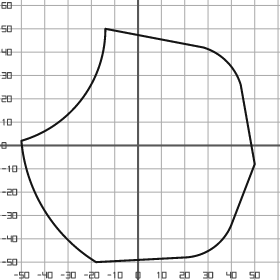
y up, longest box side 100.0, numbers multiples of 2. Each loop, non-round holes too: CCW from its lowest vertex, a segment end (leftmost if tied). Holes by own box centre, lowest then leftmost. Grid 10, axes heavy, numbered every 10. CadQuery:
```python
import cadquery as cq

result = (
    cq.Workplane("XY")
    .moveTo(-18.0, -50.0)
    .lineTo(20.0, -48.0)
    .threePointArc((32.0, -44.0), (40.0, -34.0))
    .lineTo(50.0, -8.0)
    .lineTo(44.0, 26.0)
    .threePointArc((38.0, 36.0), (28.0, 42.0))
    .lineTo(-14.0, 50.0)
    .threePointArc((-24.0, 20.0), (-50.0, 2.0))
    .threePointArc((-40.0, -28.0), (-18.0, -50.0))
    .close()
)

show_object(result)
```